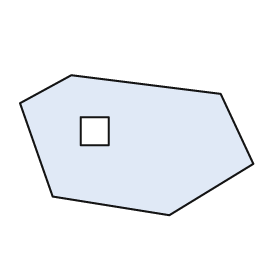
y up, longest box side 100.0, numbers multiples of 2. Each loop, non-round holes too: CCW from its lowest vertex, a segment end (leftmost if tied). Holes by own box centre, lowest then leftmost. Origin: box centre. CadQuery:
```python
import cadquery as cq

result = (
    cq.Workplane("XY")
    .moveTo(14.0, -30.0)
    .lineTo(50.0, -8.0)
    .lineTo(36.0, 22.0)
    .lineTo(-28.0, 30.0)
    .lineTo(-50.0, 18.0)
    .lineTo(-36.0, -22.0)
    .close()
    .moveTo(-24.0, 0.0)
    .lineTo(-12.0, 0.0)
    .lineTo(-12.0, 12.0)
    .lineTo(-24.0, 12.0)
    .close()
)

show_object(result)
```